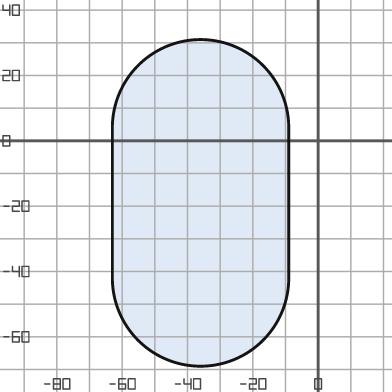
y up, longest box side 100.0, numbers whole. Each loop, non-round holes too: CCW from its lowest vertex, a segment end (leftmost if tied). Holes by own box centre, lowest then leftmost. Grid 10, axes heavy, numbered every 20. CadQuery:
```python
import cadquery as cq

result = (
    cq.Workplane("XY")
    .moveTo(-63.0, -42.0)
    .threePointArc((-36.0, -69.0), (-9.0, -42.0))
    .lineTo(-9.0, 4.0)
    .threePointArc((-36.0, 31.0), (-63.0, 4.0))
    .close()
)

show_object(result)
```